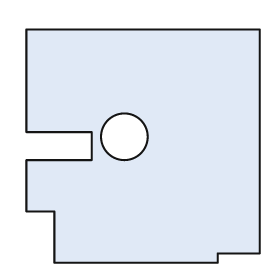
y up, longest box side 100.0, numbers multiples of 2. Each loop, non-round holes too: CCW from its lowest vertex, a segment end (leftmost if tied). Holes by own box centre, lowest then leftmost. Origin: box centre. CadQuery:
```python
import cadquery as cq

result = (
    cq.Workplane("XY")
    .moveTo(-38.0, -50.0)
    .lineTo(32.0, -50.0)
    .lineTo(32.0, -46.0)
    .lineTo(50.0, -46.0)
    .lineTo(50.0, 50.0)
    .lineTo(-50.0, 50.0)
    .lineTo(-50.0, 6.0)
    .lineTo(-22.0, 6.0)
    .lineTo(-22.0, -6.0)
    .lineTo(-50.0, -6.0)
    .lineTo(-50.0, -28.0)
    .lineTo(-38.0, -28.0)
    .close()
    .moveTo(-8.0, 4.0)
    .circle(10.0)
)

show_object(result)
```